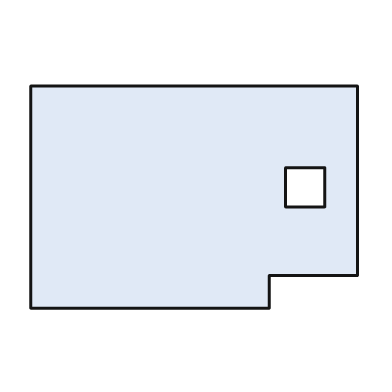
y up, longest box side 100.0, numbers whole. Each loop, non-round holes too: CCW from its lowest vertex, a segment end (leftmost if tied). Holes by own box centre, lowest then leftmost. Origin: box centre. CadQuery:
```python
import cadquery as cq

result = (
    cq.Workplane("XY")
    .moveTo(-50.0, -34.0)
    .lineTo(23.0, -34.0)
    .lineTo(23.0, -24.0)
    .lineTo(50.0, -24.0)
    .lineTo(50.0, 34.0)
    .lineTo(-50.0, 34.0)
    .close()
    .moveTo(28.0, -3.0)
    .lineTo(40.0, -3.0)
    .lineTo(40.0, 9.0)
    .lineTo(28.0, 9.0)
    .close()
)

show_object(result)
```